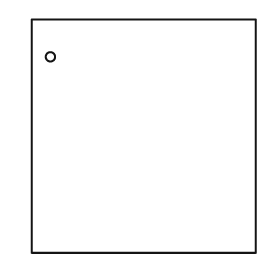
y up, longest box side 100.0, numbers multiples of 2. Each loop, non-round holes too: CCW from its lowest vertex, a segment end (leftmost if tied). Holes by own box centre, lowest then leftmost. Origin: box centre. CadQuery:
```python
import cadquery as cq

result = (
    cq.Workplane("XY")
    .moveTo(-48.0, -50.0)
    .lineTo(48.0, -50.0)
    .lineTo(48.0, 50.0)
    .lineTo(-48.0, 50.0)
    .close()
    .moveTo(-40.0, 34.0)
    .circle(2.0)
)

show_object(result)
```